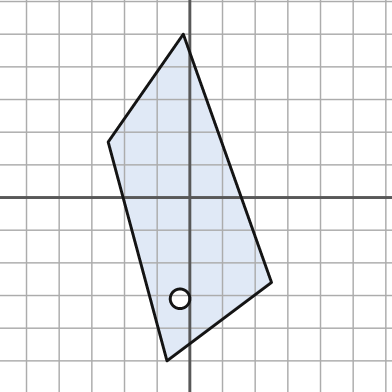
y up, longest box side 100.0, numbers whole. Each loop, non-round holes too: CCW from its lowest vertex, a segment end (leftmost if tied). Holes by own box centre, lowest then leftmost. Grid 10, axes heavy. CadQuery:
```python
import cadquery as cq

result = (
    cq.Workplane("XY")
    .moveTo(-7.0, -50.0)
    .lineTo(25.0, -26.0)
    .lineTo(-2.0, 50.0)
    .lineTo(-25.0, 17.0)
    .close()
    .moveTo(-3.0, -31.0)
    .circle(3.0)
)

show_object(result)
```